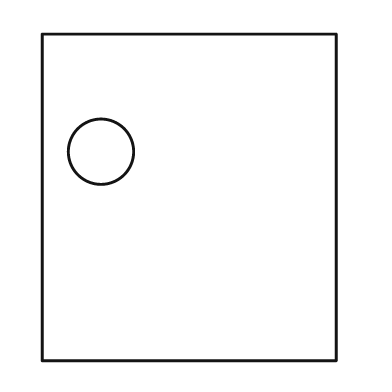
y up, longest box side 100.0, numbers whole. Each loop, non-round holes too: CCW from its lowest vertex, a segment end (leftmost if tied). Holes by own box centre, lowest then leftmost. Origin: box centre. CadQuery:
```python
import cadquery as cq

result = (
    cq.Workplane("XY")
    .moveTo(-45.0, -50.0)
    .lineTo(45.0, -50.0)
    .lineTo(45.0, 50.0)
    .lineTo(-45.0, 50.0)
    .close()
    .moveTo(-27.0, 14.0)
    .circle(10.0)
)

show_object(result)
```